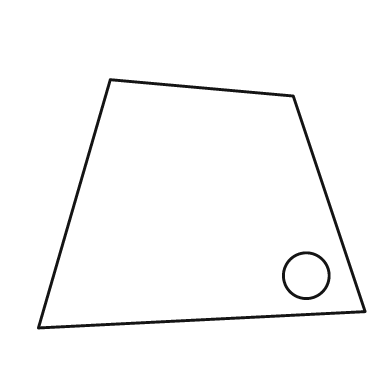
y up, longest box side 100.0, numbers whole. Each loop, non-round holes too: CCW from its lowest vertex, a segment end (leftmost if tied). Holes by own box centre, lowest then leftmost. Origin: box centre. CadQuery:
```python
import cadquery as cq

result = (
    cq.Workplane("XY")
    .moveTo(-50.0, -38.0)
    .lineTo(50.0, -33.0)
    .lineTo(28.0, 33.0)
    .lineTo(-28.0, 38.0)
    .close()
    .moveTo(32.0, -22.0)
    .circle(7.0)
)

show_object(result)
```